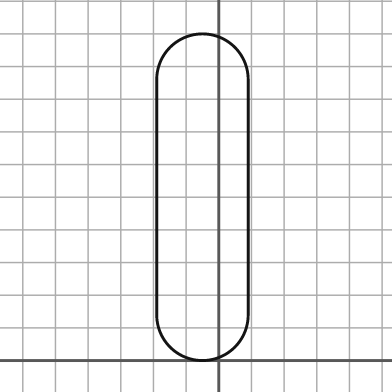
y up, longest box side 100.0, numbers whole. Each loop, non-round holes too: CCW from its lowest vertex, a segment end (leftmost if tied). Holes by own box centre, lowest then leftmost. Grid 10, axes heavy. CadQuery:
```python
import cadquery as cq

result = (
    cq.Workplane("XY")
    .moveTo(-19.0, 14.0)
    .threePointArc((-5.0, 0.0), (9.0, 14.0))
    .lineTo(9.0, 86.0)
    .threePointArc((-5.0, 100.0), (-19.0, 86.0))
    .close()
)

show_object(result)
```